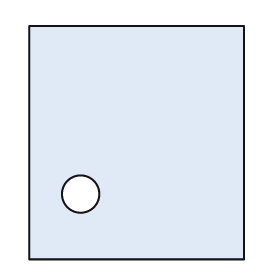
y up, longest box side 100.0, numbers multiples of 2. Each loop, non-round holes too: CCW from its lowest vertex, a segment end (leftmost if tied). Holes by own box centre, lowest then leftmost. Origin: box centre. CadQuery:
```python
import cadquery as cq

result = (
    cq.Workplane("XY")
    .moveTo(-46.0, -50.0)
    .lineTo(46.0, -50.0)
    .lineTo(46.0, 50.0)
    .lineTo(-46.0, 50.0)
    .close()
    .moveTo(-24.0, -22.0)
    .circle(8.0)
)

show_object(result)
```